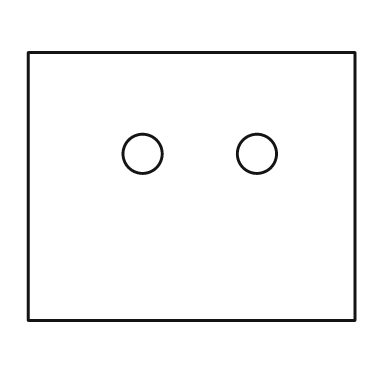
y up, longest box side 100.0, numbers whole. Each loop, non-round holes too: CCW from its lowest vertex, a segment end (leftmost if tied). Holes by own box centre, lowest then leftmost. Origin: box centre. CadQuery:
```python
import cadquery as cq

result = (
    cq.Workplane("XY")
    .moveTo(-50.0, -41.0)
    .lineTo(50.0, -41.0)
    .lineTo(50.0, 41.0)
    .lineTo(-50.0, 41.0)
    .close()
    .moveTo(-15.0, 10.0)
    .circle(6.0)
    .moveTo(20.0, 10.0)
    .circle(6.0)
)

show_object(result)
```